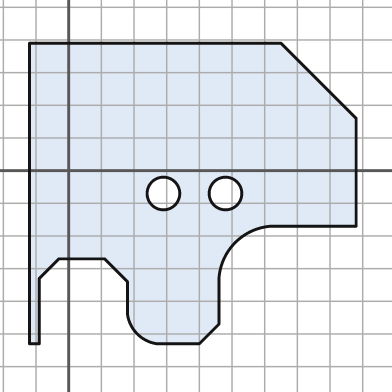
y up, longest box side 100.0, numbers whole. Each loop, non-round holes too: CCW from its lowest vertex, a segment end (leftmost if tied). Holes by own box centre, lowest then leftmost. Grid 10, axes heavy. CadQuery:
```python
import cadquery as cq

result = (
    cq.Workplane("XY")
    .moveTo(-12.0, -53.0)
    .lineTo(-9.0, -53.0)
    .lineTo(-9.0, -33.0)
    .lineTo(-3.0, -27.0)
    .lineTo(11.0, -27.0)
    .lineTo(18.0, -34.0)
    .lineTo(18.0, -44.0)
    .threePointArc((21.0, -50.0), (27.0, -53.0))
    .lineTo(40.0, -53.0)
    .lineTo(46.0, -47.0)
    .lineTo(46.0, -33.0)
    .threePointArc((51.0, -22.0), (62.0, -17.0))
    .lineTo(88.0, -17.0)
    .lineTo(88.0, 16.0)
    .lineTo(65.0, 39.0)
    .lineTo(-12.0, 39.0)
    .close()
    .moveTo(29.0, -7.0)
    .circle(5.0)
    .moveTo(48.0, -7.0)
    .circle(5.0)
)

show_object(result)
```